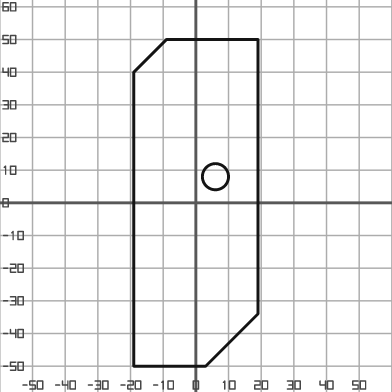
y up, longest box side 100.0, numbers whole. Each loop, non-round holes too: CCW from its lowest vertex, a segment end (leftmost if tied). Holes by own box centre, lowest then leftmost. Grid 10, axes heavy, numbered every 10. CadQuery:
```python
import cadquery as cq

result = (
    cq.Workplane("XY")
    .moveTo(-19.0, -50.0)
    .lineTo(3.0, -50.0)
    .lineTo(19.0, -34.0)
    .lineTo(19.0, 50.0)
    .lineTo(-9.0, 50.0)
    .lineTo(-19.0, 40.0)
    .close()
    .moveTo(6.0, 8.0)
    .circle(4.0)
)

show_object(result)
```